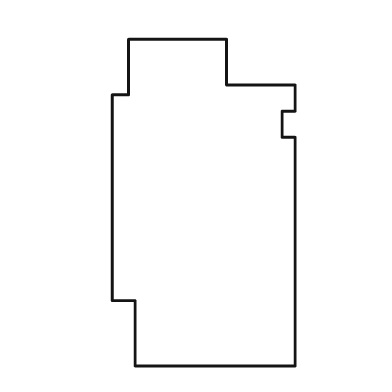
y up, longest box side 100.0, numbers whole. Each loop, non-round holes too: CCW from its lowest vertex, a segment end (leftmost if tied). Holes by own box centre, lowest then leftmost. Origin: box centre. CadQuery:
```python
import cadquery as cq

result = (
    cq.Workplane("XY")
    .moveTo(-21.0, -50.0)
    .lineTo(28.0, -50.0)
    .lineTo(28.0, 20.0)
    .lineTo(24.0, 20.0)
    .lineTo(24.0, 28.0)
    .lineTo(28.0, 28.0)
    .lineTo(28.0, 36.0)
    .lineTo(7.0, 36.0)
    .lineTo(7.0, 50.0)
    .lineTo(-23.0, 50.0)
    .lineTo(-23.0, 33.0)
    .lineTo(-28.0, 33.0)
    .lineTo(-28.0, -30.0)
    .lineTo(-21.0, -30.0)
    .close()
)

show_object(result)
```